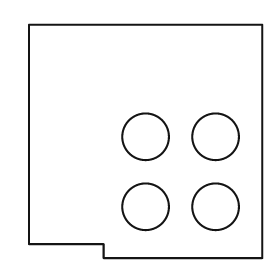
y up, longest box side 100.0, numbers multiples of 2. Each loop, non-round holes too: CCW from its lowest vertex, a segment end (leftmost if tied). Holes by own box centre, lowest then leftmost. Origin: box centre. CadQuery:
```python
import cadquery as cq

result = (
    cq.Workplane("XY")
    .moveTo(-18.0, -50.0)
    .lineTo(50.0, -50.0)
    .lineTo(50.0, 50.0)
    .lineTo(-50.0, 50.0)
    .lineTo(-50.0, -44.0)
    .lineTo(-18.0, -44.0)
    .close()
    .moveTo(0.0, -28.0)
    .circle(10.0)
    .moveTo(30.0, -28.0)
    .circle(10.0)
    .moveTo(0.0, 2.0)
    .circle(10.0)
    .moveTo(30.0, 2.0)
    .circle(10.0)
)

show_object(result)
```